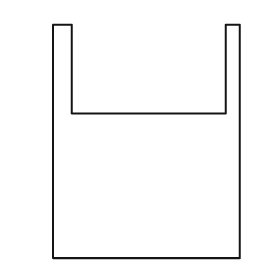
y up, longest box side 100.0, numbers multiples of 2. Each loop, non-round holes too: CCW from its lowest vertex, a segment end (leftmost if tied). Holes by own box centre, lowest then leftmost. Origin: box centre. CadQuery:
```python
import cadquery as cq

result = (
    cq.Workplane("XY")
    .moveTo(-40.0, -50.0)
    .lineTo(40.0, -50.0)
    .lineTo(40.0, 50.0)
    .lineTo(34.0, 50.0)
    .lineTo(34.0, 12.0)
    .lineTo(-32.0, 12.0)
    .lineTo(-32.0, 50.0)
    .lineTo(-40.0, 50.0)
    .close()
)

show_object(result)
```